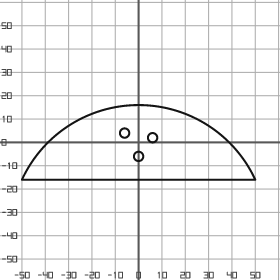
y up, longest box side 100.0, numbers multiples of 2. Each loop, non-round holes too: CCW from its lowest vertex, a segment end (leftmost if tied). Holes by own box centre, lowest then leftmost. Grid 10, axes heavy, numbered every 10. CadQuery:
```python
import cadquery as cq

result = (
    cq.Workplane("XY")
    .moveTo(-50.0, -16.0)
    .lineTo(50.0, -16.0)
    .threePointArc((0.0, 16.0), (-50.0, -16.0))
    .close()
    .moveTo(0.0, -6.0)
    .circle(2.0)
    .moveTo(6.0, 2.0)
    .circle(2.0)
    .moveTo(-6.0, 4.0)
    .circle(2.0)
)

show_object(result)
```